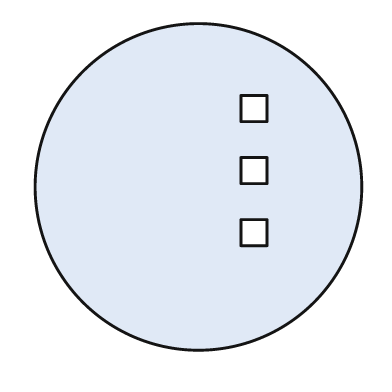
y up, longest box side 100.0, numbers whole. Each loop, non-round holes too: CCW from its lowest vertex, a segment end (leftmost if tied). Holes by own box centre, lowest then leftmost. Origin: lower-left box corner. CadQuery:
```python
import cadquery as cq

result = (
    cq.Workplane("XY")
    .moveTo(50.0, 50.0)
    .circle(50.0)
    .moveTo(63.0, 32.0)
    .lineTo(71.0, 32.0)
    .lineTo(71.0, 40.0)
    .lineTo(63.0, 40.0)
    .close()
    .moveTo(63.0, 51.0)
    .lineTo(71.0, 51.0)
    .lineTo(71.0, 59.0)
    .lineTo(63.0, 59.0)
    .close()
    .moveTo(63.0, 70.0)
    .lineTo(71.0, 70.0)
    .lineTo(71.0, 78.0)
    .lineTo(63.0, 78.0)
    .close()
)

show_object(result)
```